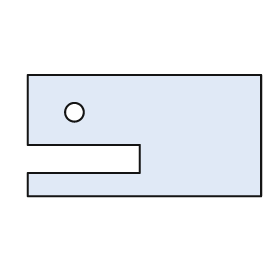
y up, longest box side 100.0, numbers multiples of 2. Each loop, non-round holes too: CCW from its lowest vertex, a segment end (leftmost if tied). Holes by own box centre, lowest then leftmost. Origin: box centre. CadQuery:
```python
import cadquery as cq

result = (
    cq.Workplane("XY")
    .moveTo(-50.0, -26.0)
    .lineTo(50.0, -26.0)
    .lineTo(50.0, 26.0)
    .lineTo(-50.0, 26.0)
    .lineTo(-50.0, -4.0)
    .lineTo(-2.0, -4.0)
    .lineTo(-2.0, -16.0)
    .lineTo(-50.0, -16.0)
    .close()
    .moveTo(-30.0, 10.0)
    .circle(4.0)
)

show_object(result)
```